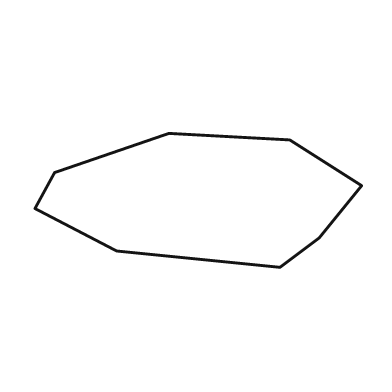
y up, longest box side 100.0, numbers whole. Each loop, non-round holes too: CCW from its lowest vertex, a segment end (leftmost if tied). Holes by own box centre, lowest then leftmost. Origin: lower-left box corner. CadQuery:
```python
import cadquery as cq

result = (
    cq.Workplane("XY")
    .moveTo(75.0, 0.0)
    .lineTo(87.0, 9.0)
    .lineTo(100.0, 25.0)
    .lineTo(78.0, 39.0)
    .lineTo(41.0, 41.0)
    .lineTo(6.0, 29.0)
    .lineTo(0.0, 18.0)
    .lineTo(25.0, 5.0)
    .close()
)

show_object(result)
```